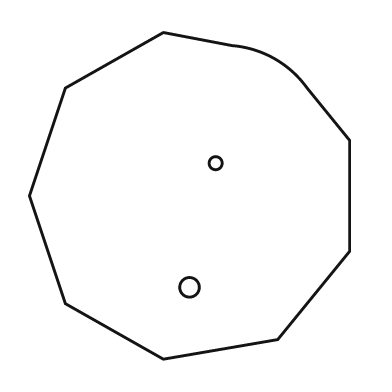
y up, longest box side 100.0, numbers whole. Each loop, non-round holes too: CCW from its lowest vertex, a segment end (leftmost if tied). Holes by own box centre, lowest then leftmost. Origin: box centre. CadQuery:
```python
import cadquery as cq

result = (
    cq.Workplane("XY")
    .moveTo(-8.0, -50.0)
    .lineTo(27.0, -44.0)
    .lineTo(49.0, -17.0)
    .lineTo(49.0, 17.0)
    .lineTo(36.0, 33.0)
    .threePointArc((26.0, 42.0), (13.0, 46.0))
    .lineTo(-8.0, 50.0)
    .lineTo(-38.0, 33.0)
    .lineTo(-49.0, 0.0)
    .lineTo(-38.0, -33.0)
    .close()
    .moveTo(0.0, -28.0)
    .circle(3.0)
    .moveTo(8.0, 10.0)
    .circle(2.0)
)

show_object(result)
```